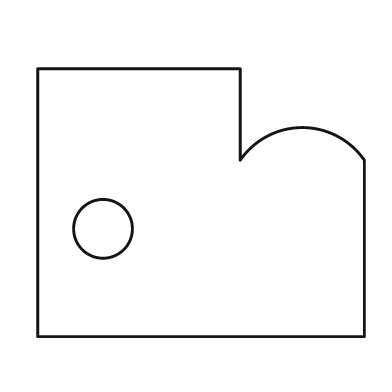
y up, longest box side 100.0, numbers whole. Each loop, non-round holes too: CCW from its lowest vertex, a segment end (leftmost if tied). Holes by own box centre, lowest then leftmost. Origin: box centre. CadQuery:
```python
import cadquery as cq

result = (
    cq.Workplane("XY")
    .moveTo(-50.0, -41.0)
    .lineTo(50.0, -41.0)
    .lineTo(50.0, 13.0)
    .threePointArc((31.0, 23.0), (12.0, 13.0))
    .lineTo(12.0, 41.0)
    .lineTo(-50.0, 41.0)
    .close()
    .moveTo(-30.0, -8.0)
    .circle(9.0)
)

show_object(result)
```